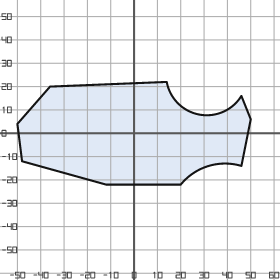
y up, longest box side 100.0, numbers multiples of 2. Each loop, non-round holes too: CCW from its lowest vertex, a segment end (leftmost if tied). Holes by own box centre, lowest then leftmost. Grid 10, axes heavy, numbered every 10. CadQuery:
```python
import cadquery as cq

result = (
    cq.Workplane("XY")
    .moveTo(-12.0, -22.0)
    .lineTo(20.0, -22.0)
    .threePointArc((32.0, -14.0), (46.0, -14.0))
    .lineTo(50.0, 6.0)
    .lineTo(46.0, 16.0)
    .threePointArc((28.0, 8.0), (14.0, 22.0))
    .lineTo(-36.0, 20.0)
    .lineTo(-50.0, 4.0)
    .lineTo(-48.0, -12.0)
    .close()
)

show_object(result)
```